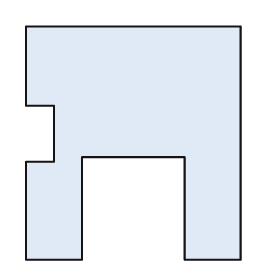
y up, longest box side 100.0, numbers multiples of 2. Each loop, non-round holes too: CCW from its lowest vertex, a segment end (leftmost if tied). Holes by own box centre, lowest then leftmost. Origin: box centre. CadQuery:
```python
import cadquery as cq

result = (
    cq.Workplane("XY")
    .moveTo(-46.0, -50.0)
    .lineTo(-22.0, -50.0)
    .lineTo(-22.0, -6.0)
    .lineTo(22.0, -6.0)
    .lineTo(22.0, -50.0)
    .lineTo(46.0, -50.0)
    .lineTo(46.0, 50.0)
    .lineTo(-46.0, 50.0)
    .lineTo(-46.0, 16.0)
    .lineTo(-34.0, 16.0)
    .lineTo(-34.0, -8.0)
    .lineTo(-46.0, -8.0)
    .close()
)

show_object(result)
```